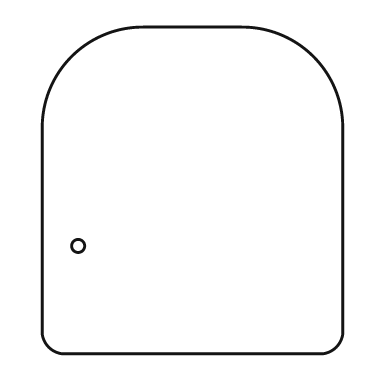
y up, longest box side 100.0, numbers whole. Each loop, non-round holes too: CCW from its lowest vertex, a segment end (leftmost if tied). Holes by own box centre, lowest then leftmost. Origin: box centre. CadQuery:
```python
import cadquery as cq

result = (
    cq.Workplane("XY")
    .moveTo(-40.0, -50.0)
    .lineTo(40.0, -50.0)
    .threePointArc((44.0, -48.0), (46.0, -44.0))
    .lineTo(46.0, 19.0)
    .threePointArc((37.0, 41.0), (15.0, 50.0))
    .lineTo(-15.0, 50.0)
    .threePointArc((-37.0, 41.0), (-46.0, 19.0))
    .lineTo(-46.0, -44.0)
    .threePointArc((-44.0, -48.0), (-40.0, -50.0))
    .close()
    .moveTo(-35.0, -17.0)
    .circle(2.0)
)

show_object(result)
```